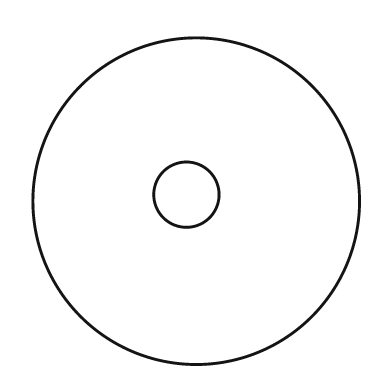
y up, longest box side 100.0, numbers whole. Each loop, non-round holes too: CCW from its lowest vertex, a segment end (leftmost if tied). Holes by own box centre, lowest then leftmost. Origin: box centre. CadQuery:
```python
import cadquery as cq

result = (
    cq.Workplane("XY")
    .moveTo(0.0, 0.0)
    .circle(50.0)
    .moveTo(-3.0, 2.0)
    .circle(10.0)
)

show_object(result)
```